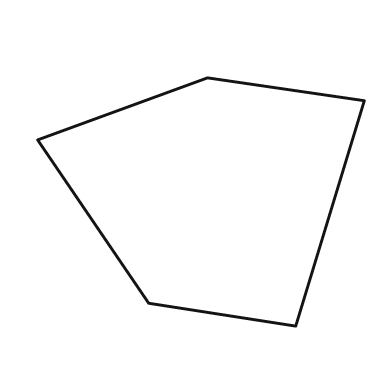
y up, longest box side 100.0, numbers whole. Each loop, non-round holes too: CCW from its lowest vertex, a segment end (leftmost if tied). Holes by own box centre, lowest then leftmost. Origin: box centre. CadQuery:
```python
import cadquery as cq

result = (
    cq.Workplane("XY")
    .moveTo(29.0, -38.0)
    .lineTo(50.0, 31.0)
    .lineTo(2.0, 38.0)
    .lineTo(-50.0, 19.0)
    .lineTo(-16.0, -31.0)
    .close()
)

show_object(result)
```